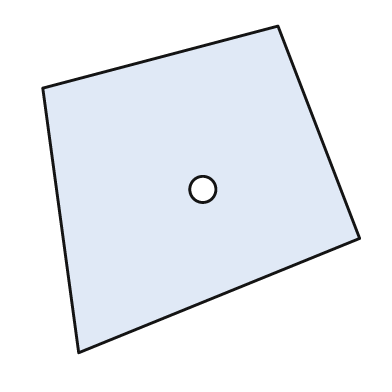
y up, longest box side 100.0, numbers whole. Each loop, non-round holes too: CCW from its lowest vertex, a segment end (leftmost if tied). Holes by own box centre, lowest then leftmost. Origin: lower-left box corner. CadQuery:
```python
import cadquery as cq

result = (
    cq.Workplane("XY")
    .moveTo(11.0, 0.0)
    .lineTo(97.0, 35.0)
    .lineTo(72.0, 100.0)
    .lineTo(0.0, 81.0)
    .close()
    .moveTo(49.0, 50.0)
    .circle(4.0)
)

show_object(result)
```